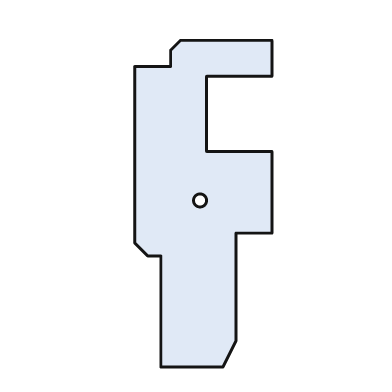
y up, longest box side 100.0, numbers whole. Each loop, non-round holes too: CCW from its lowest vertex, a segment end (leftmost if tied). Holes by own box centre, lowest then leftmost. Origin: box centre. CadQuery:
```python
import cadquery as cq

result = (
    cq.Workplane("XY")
    .moveTo(-13.0, -50.0)
    .lineTo(6.0, -50.0)
    .lineTo(10.0, -42.0)
    .lineTo(10.0, -9.0)
    .lineTo(21.0, -9.0)
    .lineTo(21.0, 16.0)
    .lineTo(1.0, 16.0)
    .lineTo(1.0, 39.0)
    .lineTo(21.0, 39.0)
    .lineTo(21.0, 50.0)
    .lineTo(-7.0, 50.0)
    .lineTo(-10.0, 47.0)
    .lineTo(-10.0, 42.0)
    .lineTo(-21.0, 42.0)
    .lineTo(-21.0, -12.0)
    .lineTo(-17.0, -16.0)
    .lineTo(-13.0, -16.0)
    .close()
    .moveTo(-1.0, 1.0)
    .circle(2.0)
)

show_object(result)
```